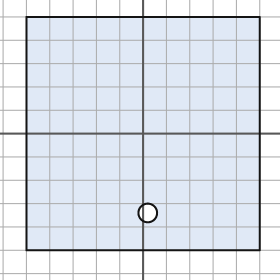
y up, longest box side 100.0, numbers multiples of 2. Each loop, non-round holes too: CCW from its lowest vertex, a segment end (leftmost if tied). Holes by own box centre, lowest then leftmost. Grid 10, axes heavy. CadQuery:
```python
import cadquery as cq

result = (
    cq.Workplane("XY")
    .moveTo(-50.0, -50.0)
    .lineTo(50.0, -50.0)
    .lineTo(50.0, 50.0)
    .lineTo(-50.0, 50.0)
    .close()
    .moveTo(2.0, -34.0)
    .circle(4.0)
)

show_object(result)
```